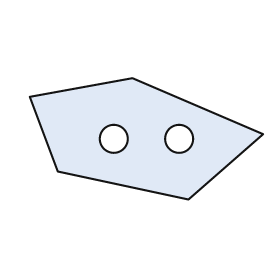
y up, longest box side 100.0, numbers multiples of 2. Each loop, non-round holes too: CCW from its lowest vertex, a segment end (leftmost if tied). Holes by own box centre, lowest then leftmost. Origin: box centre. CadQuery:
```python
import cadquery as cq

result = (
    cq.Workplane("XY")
    .moveTo(18.0, -26.0)
    .lineTo(50.0, 2.0)
    .lineTo(-6.0, 26.0)
    .lineTo(-50.0, 18.0)
    .lineTo(-38.0, -14.0)
    .close()
    .moveTo(-14.0, 0.0)
    .circle(6.0)
    .moveTo(14.0, 0.0)
    .circle(6.0)
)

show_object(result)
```